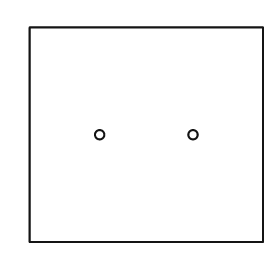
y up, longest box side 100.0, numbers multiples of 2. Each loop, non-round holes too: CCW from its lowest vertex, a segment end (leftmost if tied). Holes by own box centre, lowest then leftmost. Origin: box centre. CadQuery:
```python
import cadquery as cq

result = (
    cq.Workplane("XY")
    .moveTo(-50.0, -46.0)
    .lineTo(50.0, -46.0)
    .lineTo(50.0, 46.0)
    .lineTo(-50.0, 46.0)
    .close()
    .moveTo(-20.0, 0.0)
    .circle(2.0)
    .moveTo(20.0, 0.0)
    .circle(2.0)
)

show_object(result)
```